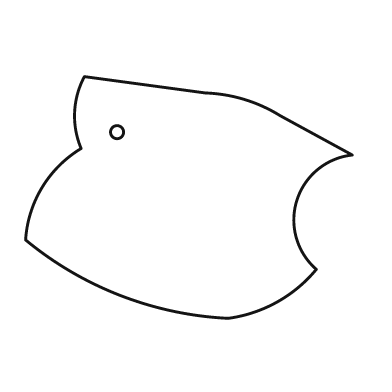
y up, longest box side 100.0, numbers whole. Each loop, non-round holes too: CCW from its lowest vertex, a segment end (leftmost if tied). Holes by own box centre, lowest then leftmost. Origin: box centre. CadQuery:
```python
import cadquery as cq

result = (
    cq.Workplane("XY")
    .moveTo(12.0, -37.0)
    .threePointArc((27.0, -32.0), (39.0, -22.0))
    .threePointArc((33.0, -1.0), (50.0, 13.0))
    .lineTo(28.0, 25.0)
    .threePointArc((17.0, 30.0), (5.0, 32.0))
    .lineTo(-32.0, 37.0)
    .threePointArc((-35.0, 26.0), (-33.0, 15.0))
    .threePointArc((-45.0, 3.0), (-50.0, -13.0))
    .threePointArc((-21.0, -30.0), (12.0, -37.0))
    .close()
    .moveTo(-22.0, 20.0)
    .circle(2.0)
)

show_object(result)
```